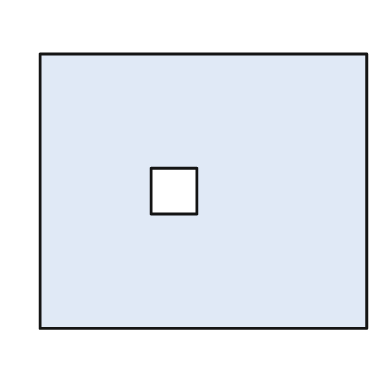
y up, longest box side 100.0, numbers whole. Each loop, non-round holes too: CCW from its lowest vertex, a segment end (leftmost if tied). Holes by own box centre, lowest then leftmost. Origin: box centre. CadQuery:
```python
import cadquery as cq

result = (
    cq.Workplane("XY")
    .moveTo(-50.0, -42.0)
    .lineTo(50.0, -42.0)
    .lineTo(50.0, 42.0)
    .lineTo(-50.0, 42.0)
    .close()
    .moveTo(-16.0, -7.0)
    .lineTo(-2.0, -7.0)
    .lineTo(-2.0, 7.0)
    .lineTo(-16.0, 7.0)
    .close()
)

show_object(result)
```